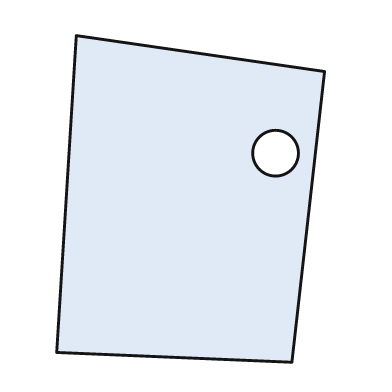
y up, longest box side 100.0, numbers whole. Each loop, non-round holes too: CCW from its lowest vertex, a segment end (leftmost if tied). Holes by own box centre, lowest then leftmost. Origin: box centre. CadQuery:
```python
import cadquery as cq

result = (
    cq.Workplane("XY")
    .moveTo(31.0, -50.0)
    .lineTo(41.0, 39.0)
    .lineTo(-35.0, 50.0)
    .lineTo(-41.0, -47.0)
    .close()
    .moveTo(26.0, 14.0)
    .circle(7.0)
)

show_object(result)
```